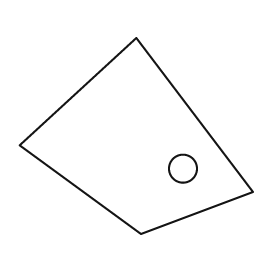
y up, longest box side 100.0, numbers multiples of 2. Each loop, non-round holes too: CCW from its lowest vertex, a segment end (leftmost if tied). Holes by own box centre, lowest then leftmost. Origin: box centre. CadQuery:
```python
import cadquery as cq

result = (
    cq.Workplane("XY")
    .moveTo(2.0, -42.0)
    .lineTo(50.0, -24.0)
    .lineTo(0.0, 42.0)
    .lineTo(-50.0, -4.0)
    .close()
    .moveTo(20.0, -14.0)
    .circle(6.0)
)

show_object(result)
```